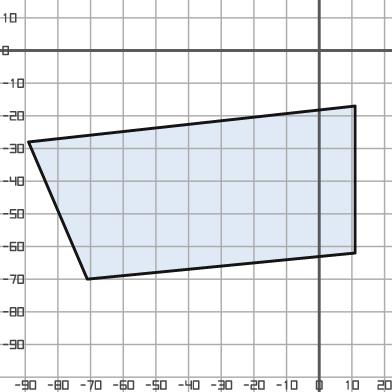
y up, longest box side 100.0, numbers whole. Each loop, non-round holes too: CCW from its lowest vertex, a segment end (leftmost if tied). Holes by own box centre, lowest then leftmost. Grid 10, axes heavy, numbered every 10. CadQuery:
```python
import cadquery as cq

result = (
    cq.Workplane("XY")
    .moveTo(-71.0, -70.0)
    .lineTo(11.0, -62.0)
    .lineTo(11.0, -17.0)
    .lineTo(-89.0, -28.0)
    .close()
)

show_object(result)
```